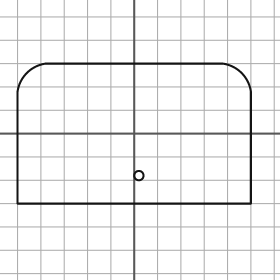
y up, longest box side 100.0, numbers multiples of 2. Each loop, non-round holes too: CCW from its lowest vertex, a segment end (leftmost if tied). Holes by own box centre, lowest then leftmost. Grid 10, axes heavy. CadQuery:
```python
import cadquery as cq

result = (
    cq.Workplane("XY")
    .moveTo(-50.0, -30.0)
    .lineTo(50.0, -30.0)
    .lineTo(50.0, 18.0)
    .threePointArc((46.0, 26.0), (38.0, 30.0))
    .lineTo(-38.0, 30.0)
    .threePointArc((-46.0, 26.0), (-50.0, 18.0))
    .close()
    .moveTo(2.0, -18.0)
    .circle(2.0)
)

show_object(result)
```